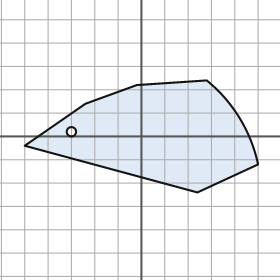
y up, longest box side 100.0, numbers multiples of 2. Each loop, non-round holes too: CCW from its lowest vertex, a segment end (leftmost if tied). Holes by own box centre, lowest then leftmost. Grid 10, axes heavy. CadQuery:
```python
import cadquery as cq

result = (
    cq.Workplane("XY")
    .moveTo(24.0, -24.0)
    .lineTo(50.0, -12.0)
    .threePointArc((42.0, 8.0), (28.0, 24.0))
    .lineTo(-2.0, 22.0)
    .lineTo(-24.0, 14.0)
    .lineTo(-50.0, -4.0)
    .close()
    .moveTo(-30.0, 2.0)
    .circle(2.0)
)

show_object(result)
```